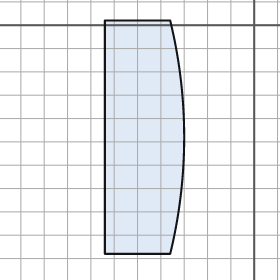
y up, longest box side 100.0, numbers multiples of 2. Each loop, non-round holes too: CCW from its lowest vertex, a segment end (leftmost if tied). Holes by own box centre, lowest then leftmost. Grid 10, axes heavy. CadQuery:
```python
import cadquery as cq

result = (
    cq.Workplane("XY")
    .moveTo(-64.0, -98.0)
    .lineTo(-36.0, -98.0)
    .threePointArc((-30.0, -48.0), (-36.0, 2.0))
    .lineTo(-64.0, 2.0)
    .close()
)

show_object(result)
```